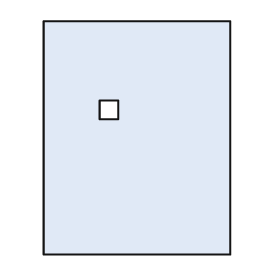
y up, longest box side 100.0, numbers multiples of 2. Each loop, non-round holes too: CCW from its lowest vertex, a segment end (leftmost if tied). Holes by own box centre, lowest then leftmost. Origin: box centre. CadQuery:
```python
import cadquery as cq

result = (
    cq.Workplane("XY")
    .moveTo(-40.0, -50.0)
    .lineTo(40.0, -50.0)
    .lineTo(40.0, 50.0)
    .lineTo(-40.0, 50.0)
    .close()
    .moveTo(-16.0, 8.0)
    .lineTo(-8.0, 8.0)
    .lineTo(-8.0, 16.0)
    .lineTo(-16.0, 16.0)
    .close()
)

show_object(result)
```